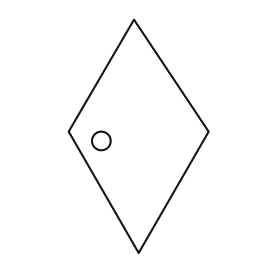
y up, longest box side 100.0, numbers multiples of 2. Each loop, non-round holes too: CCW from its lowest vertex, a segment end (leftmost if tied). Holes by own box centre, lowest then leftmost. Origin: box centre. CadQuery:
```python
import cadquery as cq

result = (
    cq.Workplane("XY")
    .moveTo(0.0, -50.0)
    .lineTo(30.0, 2.0)
    .lineTo(-2.0, 50.0)
    .lineTo(-30.0, 2.0)
    .close()
    .moveTo(-16.0, -2.0)
    .circle(4.0)
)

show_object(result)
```